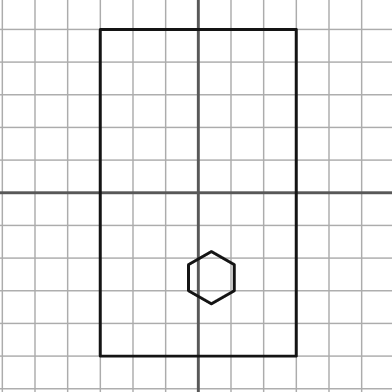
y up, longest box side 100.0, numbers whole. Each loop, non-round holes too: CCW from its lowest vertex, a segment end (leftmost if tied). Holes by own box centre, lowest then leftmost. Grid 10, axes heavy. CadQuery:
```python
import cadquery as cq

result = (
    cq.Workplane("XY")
    .moveTo(-30.0, -50.0)
    .lineTo(30.0, -50.0)
    .lineTo(30.0, 50.0)
    .lineTo(-30.0, 50.0)
    .close()
    .moveTo(4.0, -34.0)
    .lineTo(11.0, -30.0)
    .lineTo(11.0, -22.0)
    .lineTo(4.0, -18.0)
    .lineTo(-3.0, -22.0)
    .lineTo(-3.0, -30.0)
    .close()
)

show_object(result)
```